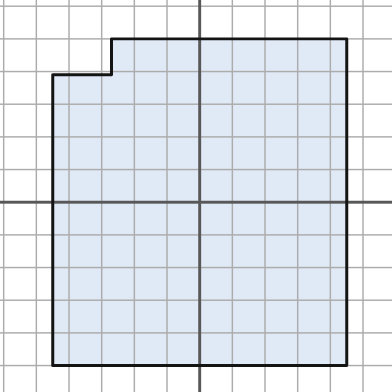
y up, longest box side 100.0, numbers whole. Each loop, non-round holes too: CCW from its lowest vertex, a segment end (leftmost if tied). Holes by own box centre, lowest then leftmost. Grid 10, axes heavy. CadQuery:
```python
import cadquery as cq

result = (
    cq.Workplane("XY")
    .moveTo(-45.0, -50.0)
    .lineTo(45.0, -50.0)
    .lineTo(45.0, 50.0)
    .lineTo(-27.0, 50.0)
    .lineTo(-27.0, 39.0)
    .lineTo(-45.0, 39.0)
    .close()
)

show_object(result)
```